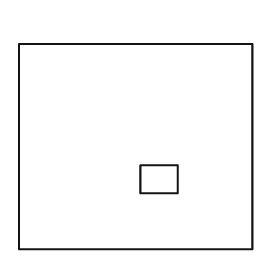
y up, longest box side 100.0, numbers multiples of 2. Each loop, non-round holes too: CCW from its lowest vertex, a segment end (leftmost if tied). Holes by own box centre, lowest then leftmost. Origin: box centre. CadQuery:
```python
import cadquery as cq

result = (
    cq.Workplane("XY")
    .moveTo(-50.0, -44.0)
    .lineTo(50.0, -44.0)
    .lineTo(50.0, 44.0)
    .lineTo(-50.0, 44.0)
    .close()
    .moveTo(2.0, -20.0)
    .lineTo(18.0, -20.0)
    .lineTo(18.0, -8.0)
    .lineTo(2.0, -8.0)
    .close()
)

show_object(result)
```